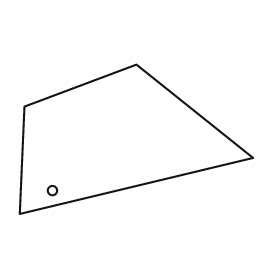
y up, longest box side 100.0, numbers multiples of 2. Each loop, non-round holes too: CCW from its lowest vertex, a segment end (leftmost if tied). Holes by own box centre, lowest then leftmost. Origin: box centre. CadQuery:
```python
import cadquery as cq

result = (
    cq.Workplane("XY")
    .moveTo(-50.0, -32.0)
    .lineTo(50.0, -8.0)
    .lineTo(0.0, 32.0)
    .lineTo(-48.0, 14.0)
    .close()
    .moveTo(-36.0, -22.0)
    .circle(2.0)
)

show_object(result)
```